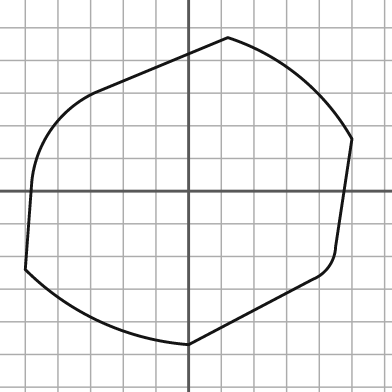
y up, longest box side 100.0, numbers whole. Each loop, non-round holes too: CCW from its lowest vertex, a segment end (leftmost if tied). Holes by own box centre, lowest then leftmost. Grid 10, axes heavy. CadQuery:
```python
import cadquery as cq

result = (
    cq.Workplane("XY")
    .moveTo(0.0, -47.0)
    .lineTo(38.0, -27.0)
    .threePointArc((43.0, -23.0), (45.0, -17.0))
    .lineTo(50.0, 16.0)
    .threePointArc((34.0, 35.0), (12.0, 47.0))
    .lineTo(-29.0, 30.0)
    .threePointArc((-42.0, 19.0), (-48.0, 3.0))
    .lineTo(-50.0, -24.0)
    .threePointArc((-27.0, -40.0), (0.0, -47.0))
    .close()
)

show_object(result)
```